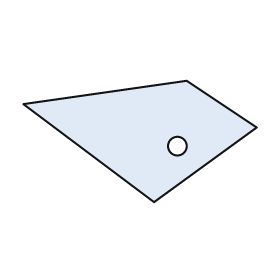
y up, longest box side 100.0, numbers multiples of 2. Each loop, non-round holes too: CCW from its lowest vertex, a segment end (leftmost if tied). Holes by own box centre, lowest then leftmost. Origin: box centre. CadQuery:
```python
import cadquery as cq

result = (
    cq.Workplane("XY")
    .moveTo(6.0, -26.0)
    .lineTo(50.0, 6.0)
    .lineTo(20.0, 26.0)
    .lineTo(-50.0, 16.0)
    .close()
    .moveTo(16.0, -2.0)
    .circle(4.0)
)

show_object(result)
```